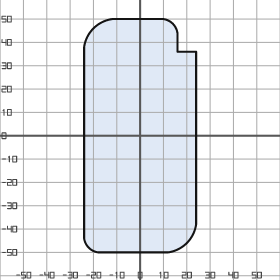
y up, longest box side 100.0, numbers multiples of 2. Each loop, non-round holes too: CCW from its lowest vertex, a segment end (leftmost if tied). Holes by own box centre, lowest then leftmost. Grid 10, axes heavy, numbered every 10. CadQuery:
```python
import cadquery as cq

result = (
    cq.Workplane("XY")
    .moveTo(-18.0, -50.0)
    .lineTo(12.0, -50.0)
    .threePointArc((20.0, -46.0), (24.0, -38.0))
    .lineTo(24.0, 36.0)
    .lineTo(16.0, 36.0)
    .lineTo(16.0, 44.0)
    .threePointArc((14.0, 48.0), (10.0, 50.0))
    .lineTo(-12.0, 50.0)
    .threePointArc((-20.0, 46.0), (-24.0, 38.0))
    .lineTo(-24.0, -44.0)
    .threePointArc((-22.0, -48.0), (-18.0, -50.0))
    .close()
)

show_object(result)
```